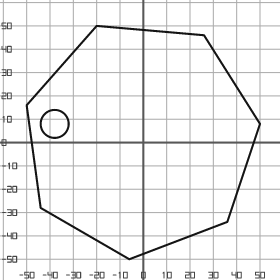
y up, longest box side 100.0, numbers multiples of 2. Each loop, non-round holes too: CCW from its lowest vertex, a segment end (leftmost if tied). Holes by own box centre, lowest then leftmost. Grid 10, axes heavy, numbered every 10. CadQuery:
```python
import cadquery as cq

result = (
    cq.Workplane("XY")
    .moveTo(-6.0, -50.0)
    .lineTo(36.0, -34.0)
    .lineTo(50.0, 8.0)
    .lineTo(26.0, 46.0)
    .lineTo(-20.0, 50.0)
    .lineTo(-50.0, 16.0)
    .lineTo(-44.0, -28.0)
    .close()
    .moveTo(-38.0, 8.0)
    .circle(6.0)
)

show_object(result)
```